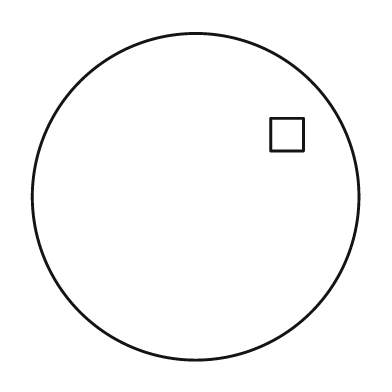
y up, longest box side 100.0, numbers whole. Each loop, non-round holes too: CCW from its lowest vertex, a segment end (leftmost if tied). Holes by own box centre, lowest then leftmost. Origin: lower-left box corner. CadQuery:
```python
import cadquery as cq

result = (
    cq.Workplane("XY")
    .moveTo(50.0, 50.0)
    .circle(50.0)
    .moveTo(73.0, 64.0)
    .lineTo(83.0, 64.0)
    .lineTo(83.0, 74.0)
    .lineTo(73.0, 74.0)
    .close()
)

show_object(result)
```